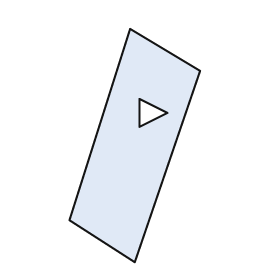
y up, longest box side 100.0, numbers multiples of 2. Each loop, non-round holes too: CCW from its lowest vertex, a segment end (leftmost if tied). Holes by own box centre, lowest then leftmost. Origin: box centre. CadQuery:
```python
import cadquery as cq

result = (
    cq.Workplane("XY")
    .moveTo(0.0, -50.0)
    .lineTo(28.0, 32.0)
    .lineTo(-2.0, 50.0)
    .lineTo(-28.0, -32.0)
    .close()
    .moveTo(2.0, 8.0)
    .lineTo(14.0, 14.0)
    .lineTo(2.0, 20.0)
    .close()
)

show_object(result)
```